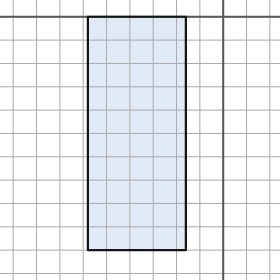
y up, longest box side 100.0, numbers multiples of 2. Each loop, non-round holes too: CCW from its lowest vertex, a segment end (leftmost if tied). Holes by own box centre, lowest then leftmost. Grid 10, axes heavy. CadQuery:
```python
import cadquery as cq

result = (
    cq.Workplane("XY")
    .moveTo(-58.0, -100.0)
    .lineTo(-16.0, -100.0)
    .lineTo(-16.0, 0.0)
    .lineTo(-58.0, 0.0)
    .close()
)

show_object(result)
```